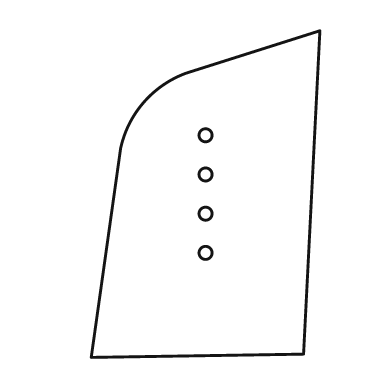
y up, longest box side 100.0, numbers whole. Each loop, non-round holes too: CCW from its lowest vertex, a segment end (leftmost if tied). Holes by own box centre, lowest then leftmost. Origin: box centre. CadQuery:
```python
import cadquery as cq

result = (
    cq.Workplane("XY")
    .moveTo(-35.0, -50.0)
    .lineTo(30.0, -49.0)
    .lineTo(35.0, 50.0)
    .lineTo(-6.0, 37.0)
    .threePointArc((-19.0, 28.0), (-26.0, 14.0))
    .close()
    .moveTo(0.0, -18.0)
    .circle(2.0)
    .moveTo(0.0, -6.0)
    .circle(2.0)
    .moveTo(0.0, 6.0)
    .circle(2.0)
    .moveTo(0.0, 18.0)
    .circle(2.0)
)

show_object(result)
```